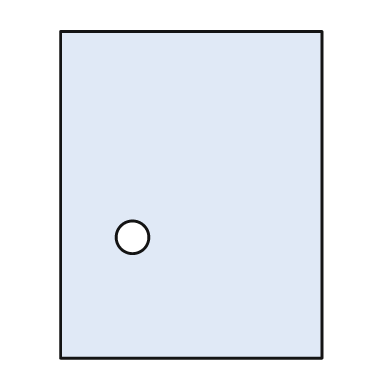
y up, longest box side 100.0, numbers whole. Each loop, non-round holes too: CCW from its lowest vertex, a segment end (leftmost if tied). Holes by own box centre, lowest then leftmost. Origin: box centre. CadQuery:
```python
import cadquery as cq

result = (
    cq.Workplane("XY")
    .moveTo(-40.0, -50.0)
    .lineTo(40.0, -50.0)
    .lineTo(40.0, 50.0)
    .lineTo(-40.0, 50.0)
    .close()
    .moveTo(-18.0, -13.0)
    .circle(5.0)
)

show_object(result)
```